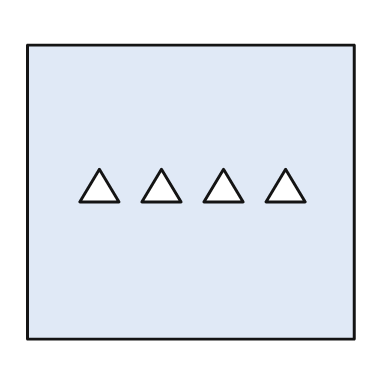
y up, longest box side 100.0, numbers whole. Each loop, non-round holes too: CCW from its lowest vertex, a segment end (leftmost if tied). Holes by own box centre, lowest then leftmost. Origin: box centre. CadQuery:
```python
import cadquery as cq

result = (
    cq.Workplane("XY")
    .moveTo(-50.0, -45.0)
    .lineTo(50.0, -45.0)
    .lineTo(50.0, 45.0)
    .lineTo(-50.0, 45.0)
    .close()
    .moveTo(-34.0, -3.0)
    .lineTo(-22.0, -3.0)
    .lineTo(-28.0, 7.0)
    .close()
    .moveTo(-15.0, -3.0)
    .lineTo(-3.0, -3.0)
    .lineTo(-9.0, 7.0)
    .close()
    .moveTo(4.0, -3.0)
    .lineTo(16.0, -3.0)
    .lineTo(10.0, 7.0)
    .close()
    .moveTo(23.0, -3.0)
    .lineTo(35.0, -3.0)
    .lineTo(29.0, 7.0)
    .close()
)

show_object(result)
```